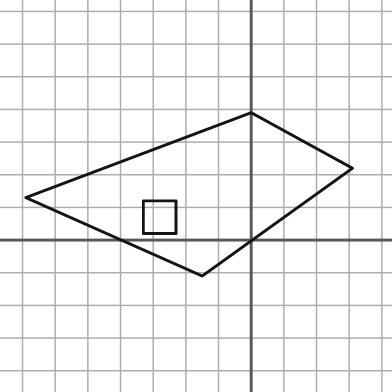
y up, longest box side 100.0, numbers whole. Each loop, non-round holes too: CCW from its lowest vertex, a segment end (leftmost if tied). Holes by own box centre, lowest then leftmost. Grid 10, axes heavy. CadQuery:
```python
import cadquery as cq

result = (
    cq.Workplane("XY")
    .moveTo(-15.0, -11.0)
    .lineTo(31.0, 22.0)
    .lineTo(0.0, 39.0)
    .lineTo(-69.0, 13.0)
    .close()
    .moveTo(-33.0, 2.0)
    .lineTo(-23.0, 2.0)
    .lineTo(-23.0, 12.0)
    .lineTo(-33.0, 12.0)
    .close()
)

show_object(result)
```